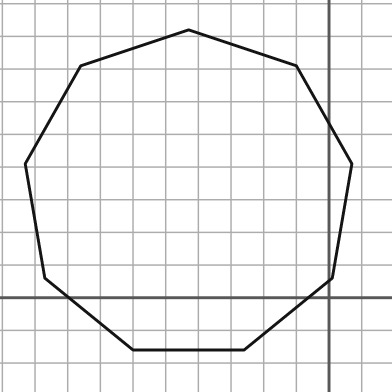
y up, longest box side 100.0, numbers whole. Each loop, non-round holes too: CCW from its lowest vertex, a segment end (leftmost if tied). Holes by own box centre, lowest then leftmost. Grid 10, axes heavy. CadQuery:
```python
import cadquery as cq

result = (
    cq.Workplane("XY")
    .moveTo(-60.0, -16.0)
    .lineTo(-26.0, -16.0)
    .lineTo(1.0, 6.0)
    .lineTo(7.0, 41.0)
    .lineTo(-10.0, 71.0)
    .lineTo(-43.0, 82.0)
    .lineTo(-76.0, 71.0)
    .lineTo(-93.0, 41.0)
    .lineTo(-87.0, 6.0)
    .close()
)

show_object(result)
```